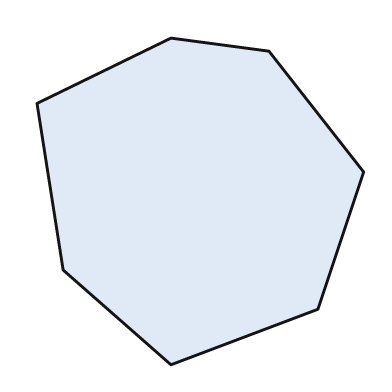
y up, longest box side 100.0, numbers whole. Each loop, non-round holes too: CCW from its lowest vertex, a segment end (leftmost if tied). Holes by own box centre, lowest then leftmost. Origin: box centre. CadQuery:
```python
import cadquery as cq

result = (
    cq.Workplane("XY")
    .moveTo(-9.0, -50.0)
    .lineTo(36.0, -33.0)
    .lineTo(50.0, 9.0)
    .lineTo(21.0, 46.0)
    .lineTo(-9.0, 50.0)
    .lineTo(-50.0, 30.0)
    .lineTo(-42.0, -21.0)
    .close()
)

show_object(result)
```